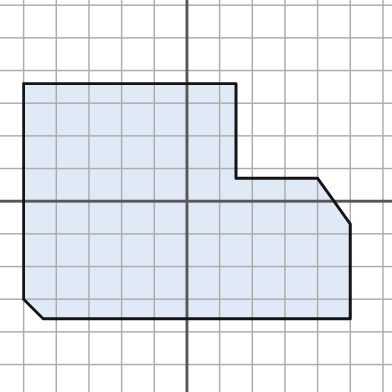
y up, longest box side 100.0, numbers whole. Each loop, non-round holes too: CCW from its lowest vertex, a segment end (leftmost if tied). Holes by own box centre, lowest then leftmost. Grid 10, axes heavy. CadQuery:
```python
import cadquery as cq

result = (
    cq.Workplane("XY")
    .moveTo(-44.0, -36.0)
    .lineTo(50.0, -36.0)
    .lineTo(50.0, -7.0)
    .lineTo(40.0, 7.0)
    .lineTo(15.0, 7.0)
    .lineTo(15.0, 36.0)
    .lineTo(-50.0, 36.0)
    .lineTo(-50.0, -30.0)
    .close()
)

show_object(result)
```